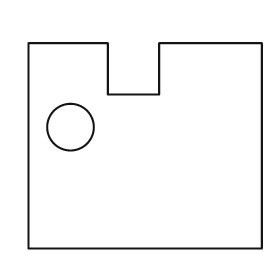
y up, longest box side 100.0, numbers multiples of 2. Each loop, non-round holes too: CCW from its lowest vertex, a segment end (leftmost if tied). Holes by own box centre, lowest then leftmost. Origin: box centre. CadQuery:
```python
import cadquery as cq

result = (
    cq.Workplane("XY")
    .moveTo(-50.0, -44.0)
    .lineTo(50.0, -44.0)
    .lineTo(50.0, 44.0)
    .lineTo(6.0, 44.0)
    .lineTo(6.0, 22.0)
    .lineTo(-16.0, 22.0)
    .lineTo(-16.0, 44.0)
    .lineTo(-50.0, 44.0)
    .close()
    .moveTo(-32.0, 8.0)
    .circle(10.0)
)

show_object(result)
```